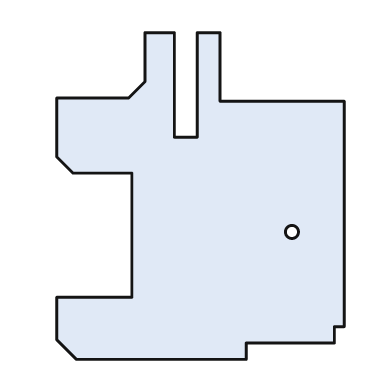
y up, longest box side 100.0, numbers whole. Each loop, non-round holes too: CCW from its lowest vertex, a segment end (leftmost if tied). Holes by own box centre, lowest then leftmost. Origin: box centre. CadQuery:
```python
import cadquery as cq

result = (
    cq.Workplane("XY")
    .moveTo(-38.0, -50.0)
    .lineTo(14.0, -50.0)
    .lineTo(14.0, -45.0)
    .lineTo(41.0, -45.0)
    .lineTo(41.0, -40.0)
    .lineTo(44.0, -40.0)
    .lineTo(44.0, 29.0)
    .lineTo(6.0, 29.0)
    .lineTo(6.0, 50.0)
    .lineTo(-1.0, 50.0)
    .lineTo(-1.0, 18.0)
    .lineTo(-8.0, 18.0)
    .lineTo(-8.0, 50.0)
    .lineTo(-17.0, 50.0)
    .lineTo(-17.0, 35.0)
    .lineTo(-22.0, 30.0)
    .lineTo(-44.0, 30.0)
    .lineTo(-44.0, 12.0)
    .lineTo(-39.0, 7.0)
    .lineTo(-21.0, 7.0)
    .lineTo(-21.0, -31.0)
    .lineTo(-44.0, -31.0)
    .lineTo(-44.0, -44.0)
    .close()
    .moveTo(28.0, -11.0)
    .circle(2.0)
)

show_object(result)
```